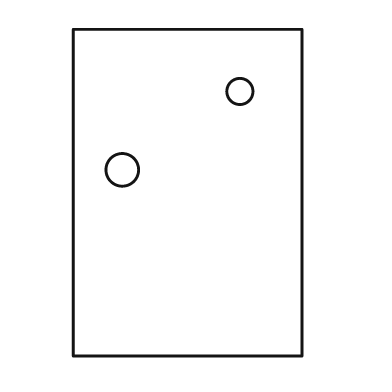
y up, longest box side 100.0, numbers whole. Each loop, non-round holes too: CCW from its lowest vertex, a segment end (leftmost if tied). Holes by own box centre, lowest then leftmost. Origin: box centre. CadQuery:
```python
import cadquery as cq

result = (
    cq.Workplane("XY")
    .moveTo(-35.0, -50.0)
    .lineTo(35.0, -50.0)
    .lineTo(35.0, 50.0)
    .lineTo(-35.0, 50.0)
    .close()
    .moveTo(-20.0, 7.0)
    .circle(5.0)
    .moveTo(16.0, 31.0)
    .circle(4.0)
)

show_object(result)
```